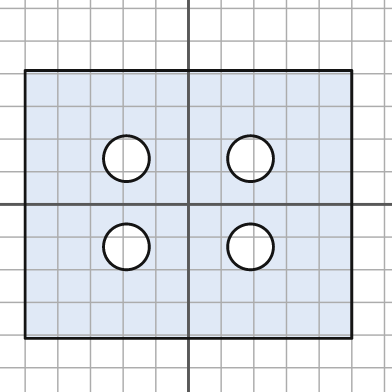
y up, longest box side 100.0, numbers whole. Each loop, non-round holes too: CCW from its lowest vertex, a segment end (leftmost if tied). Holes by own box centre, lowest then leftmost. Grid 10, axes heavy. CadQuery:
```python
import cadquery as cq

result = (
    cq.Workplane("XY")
    .moveTo(-50.0, -41.0)
    .lineTo(50.0, -41.0)
    .lineTo(50.0, 41.0)
    .lineTo(-50.0, 41.0)
    .close()
    .moveTo(-19.0, -13.0)
    .circle(7.0)
    .moveTo(19.0, -13.0)
    .circle(7.0)
    .moveTo(-19.0, 14.0)
    .circle(7.0)
    .moveTo(19.0, 14.0)
    .circle(7.0)
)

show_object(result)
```